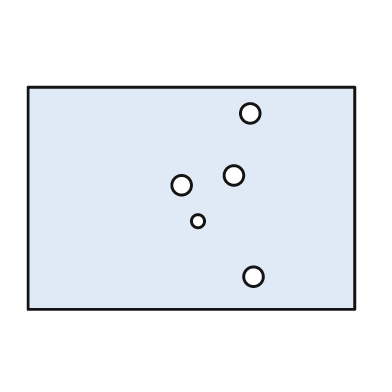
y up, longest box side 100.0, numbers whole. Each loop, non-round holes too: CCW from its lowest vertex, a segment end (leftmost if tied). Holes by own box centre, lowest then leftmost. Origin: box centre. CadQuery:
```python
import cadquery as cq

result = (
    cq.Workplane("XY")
    .moveTo(-50.0, -34.0)
    .lineTo(50.0, -34.0)
    .lineTo(50.0, 34.0)
    .lineTo(-50.0, 34.0)
    .close()
    .moveTo(19.0, -24.0)
    .circle(3.0)
    .moveTo(2.0, -7.0)
    .circle(2.0)
    .moveTo(-3.0, 4.0)
    .circle(3.0)
    .moveTo(13.0, 7.0)
    .circle(3.0)
    .moveTo(18.0, 26.0)
    .circle(3.0)
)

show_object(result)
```